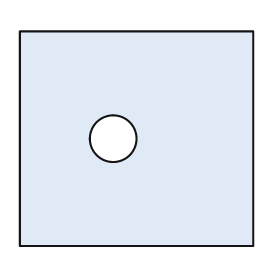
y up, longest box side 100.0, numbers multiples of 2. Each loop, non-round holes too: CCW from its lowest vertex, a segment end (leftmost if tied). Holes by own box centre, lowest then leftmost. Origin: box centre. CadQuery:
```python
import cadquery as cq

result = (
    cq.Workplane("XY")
    .moveTo(-50.0, -46.0)
    .lineTo(50.0, -46.0)
    .lineTo(50.0, 46.0)
    .lineTo(-50.0, 46.0)
    .close()
    .moveTo(-10.0, 0.0)
    .circle(10.0)
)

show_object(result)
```